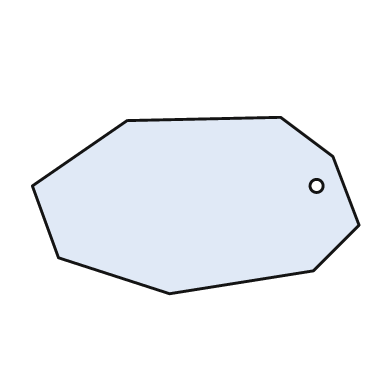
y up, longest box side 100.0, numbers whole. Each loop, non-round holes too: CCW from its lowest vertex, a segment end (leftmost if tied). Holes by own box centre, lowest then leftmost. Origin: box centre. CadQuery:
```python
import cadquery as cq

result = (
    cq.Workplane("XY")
    .moveTo(-8.0, -27.0)
    .lineTo(36.0, -20.0)
    .lineTo(50.0, -6.0)
    .lineTo(42.0, 15.0)
    .lineTo(26.0, 27.0)
    .lineTo(-21.0, 26.0)
    .lineTo(-50.0, 6.0)
    .lineTo(-42.0, -16.0)
    .close()
    .moveTo(37.0, 6.0)
    .circle(2.0)
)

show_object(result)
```